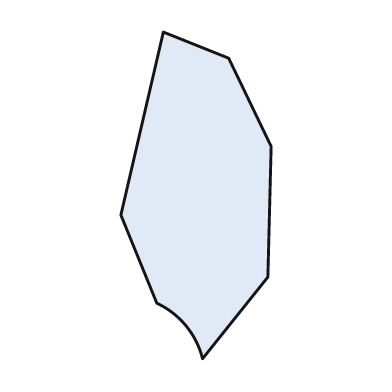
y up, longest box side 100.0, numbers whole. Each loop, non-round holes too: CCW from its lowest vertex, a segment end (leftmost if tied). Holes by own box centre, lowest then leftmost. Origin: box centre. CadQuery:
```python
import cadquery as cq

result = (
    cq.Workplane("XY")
    .moveTo(2.0, -50.0)
    .lineTo(22.0, -25.0)
    .lineTo(23.0, 15.0)
    .lineTo(10.0, 42.0)
    .lineTo(-10.0, 50.0)
    .lineTo(-23.0, -6.0)
    .lineTo(-12.0, -33.0)
    .threePointArc((-3.0, -40.0), (2.0, -50.0))
    .close()
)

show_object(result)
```